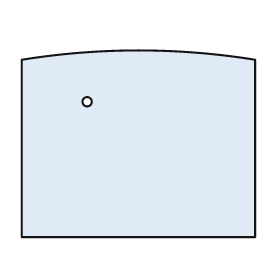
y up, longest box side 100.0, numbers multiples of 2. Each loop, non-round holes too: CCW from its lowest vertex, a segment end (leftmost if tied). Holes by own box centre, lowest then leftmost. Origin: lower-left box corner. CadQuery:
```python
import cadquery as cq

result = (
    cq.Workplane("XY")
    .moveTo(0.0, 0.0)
    .lineTo(100.0, 0.0)
    .lineTo(100.0, 76.0)
    .threePointArc((50.0, 80.0), (0.0, 76.0))
    .close()
    .moveTo(28.0, 58.0)
    .circle(2.0)
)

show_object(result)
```